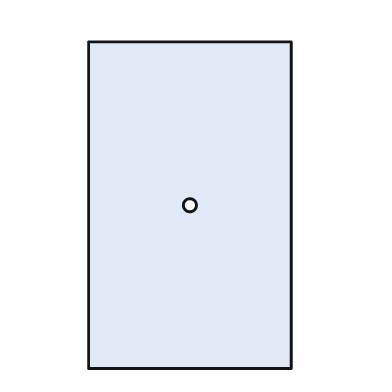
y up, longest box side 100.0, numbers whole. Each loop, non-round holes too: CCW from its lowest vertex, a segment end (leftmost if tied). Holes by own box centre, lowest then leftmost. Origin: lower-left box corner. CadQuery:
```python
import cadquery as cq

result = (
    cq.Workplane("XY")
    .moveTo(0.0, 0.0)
    .lineTo(62.0, 0.0)
    .lineTo(62.0, 100.0)
    .lineTo(0.0, 100.0)
    .close()
    .moveTo(31.0, 50.0)
    .circle(2.0)
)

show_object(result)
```